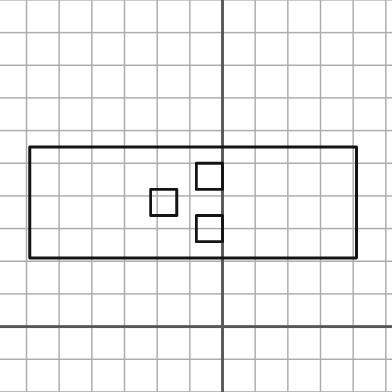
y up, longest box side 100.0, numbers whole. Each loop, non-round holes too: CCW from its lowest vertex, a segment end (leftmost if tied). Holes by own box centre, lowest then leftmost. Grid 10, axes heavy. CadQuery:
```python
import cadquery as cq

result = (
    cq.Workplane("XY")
    .moveTo(-59.0, 21.0)
    .lineTo(41.0, 21.0)
    .lineTo(41.0, 55.0)
    .lineTo(-59.0, 55.0)
    .close()
    .moveTo(-8.0, 26.0)
    .lineTo(0.0, 26.0)
    .lineTo(0.0, 34.0)
    .lineTo(-8.0, 34.0)
    .close()
    .moveTo(-22.0, 34.0)
    .lineTo(-14.0, 34.0)
    .lineTo(-14.0, 42.0)
    .lineTo(-22.0, 42.0)
    .close()
    .moveTo(-8.0, 42.0)
    .lineTo(0.0, 42.0)
    .lineTo(0.0, 50.0)
    .lineTo(-8.0, 50.0)
    .close()
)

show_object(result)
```